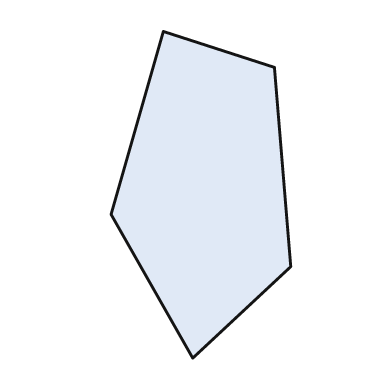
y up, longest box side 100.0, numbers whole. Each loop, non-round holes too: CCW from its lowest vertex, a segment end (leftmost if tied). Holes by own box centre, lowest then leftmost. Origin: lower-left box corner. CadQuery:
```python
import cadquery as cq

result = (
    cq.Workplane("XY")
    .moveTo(25.0, 0.0)
    .lineTo(55.0, 28.0)
    .lineTo(50.0, 89.0)
    .lineTo(16.0, 100.0)
    .lineTo(0.0, 44.0)
    .close()
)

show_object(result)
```